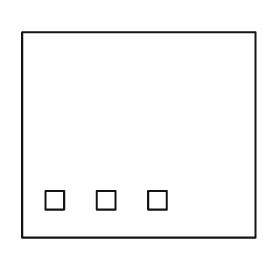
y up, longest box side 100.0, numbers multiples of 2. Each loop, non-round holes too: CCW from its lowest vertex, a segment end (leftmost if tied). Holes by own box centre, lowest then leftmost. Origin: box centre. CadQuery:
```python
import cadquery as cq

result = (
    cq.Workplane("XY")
    .moveTo(-50.0, -44.0)
    .lineTo(50.0, -44.0)
    .lineTo(50.0, 44.0)
    .lineTo(-50.0, 44.0)
    .close()
    .moveTo(-40.0, -32.0)
    .lineTo(-32.0, -32.0)
    .lineTo(-32.0, -24.0)
    .lineTo(-40.0, -24.0)
    .close()
    .moveTo(-18.0, -32.0)
    .lineTo(-10.0, -32.0)
    .lineTo(-10.0, -24.0)
    .lineTo(-18.0, -24.0)
    .close()
    .moveTo(4.0, -32.0)
    .lineTo(12.0, -32.0)
    .lineTo(12.0, -24.0)
    .lineTo(4.0, -24.0)
    .close()
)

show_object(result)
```